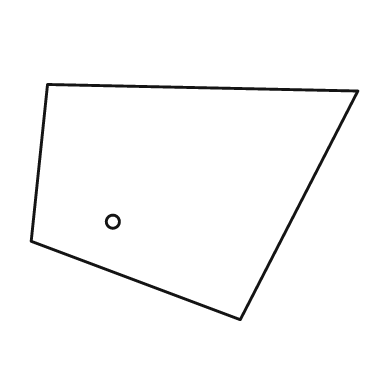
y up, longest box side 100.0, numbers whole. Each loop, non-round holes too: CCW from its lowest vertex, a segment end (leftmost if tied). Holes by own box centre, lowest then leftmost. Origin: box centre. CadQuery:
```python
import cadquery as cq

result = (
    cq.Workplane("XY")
    .moveTo(14.0, -36.0)
    .lineTo(50.0, 34.0)
    .lineTo(-45.0, 36.0)
    .lineTo(-50.0, -12.0)
    .close()
    .moveTo(-25.0, -6.0)
    .circle(2.0)
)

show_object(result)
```